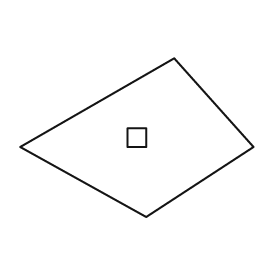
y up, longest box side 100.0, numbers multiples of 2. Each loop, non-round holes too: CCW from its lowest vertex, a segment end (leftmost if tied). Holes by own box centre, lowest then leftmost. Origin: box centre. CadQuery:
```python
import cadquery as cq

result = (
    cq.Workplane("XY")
    .moveTo(4.0, -34.0)
    .lineTo(50.0, -4.0)
    .lineTo(16.0, 34.0)
    .lineTo(-50.0, -4.0)
    .close()
    .moveTo(-4.0, -4.0)
    .lineTo(4.0, -4.0)
    .lineTo(4.0, 4.0)
    .lineTo(-4.0, 4.0)
    .close()
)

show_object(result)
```